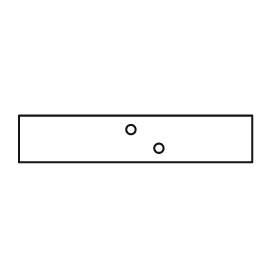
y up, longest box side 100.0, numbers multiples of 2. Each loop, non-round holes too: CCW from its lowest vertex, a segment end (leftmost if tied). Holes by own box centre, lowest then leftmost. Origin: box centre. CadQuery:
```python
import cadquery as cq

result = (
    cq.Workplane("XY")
    .moveTo(-50.0, -10.0)
    .lineTo(50.0, -10.0)
    .lineTo(50.0, 10.0)
    .lineTo(-50.0, 10.0)
    .close()
    .moveTo(10.0, -4.0)
    .circle(2.0)
    .moveTo(-2.0, 4.0)
    .circle(2.0)
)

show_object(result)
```